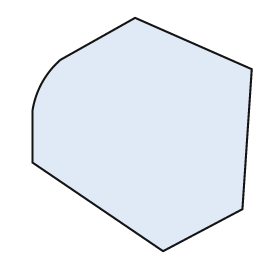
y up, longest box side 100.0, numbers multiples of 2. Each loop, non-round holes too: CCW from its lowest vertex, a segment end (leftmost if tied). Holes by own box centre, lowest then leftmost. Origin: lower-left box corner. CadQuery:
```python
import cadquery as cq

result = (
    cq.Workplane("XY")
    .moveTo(56.0, 0.0)
    .lineTo(90.0, 18.0)
    .lineTo(94.0, 78.0)
    .lineTo(44.0, 100.0)
    .lineTo(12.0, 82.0)
    .threePointArc((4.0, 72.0), (0.0, 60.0))
    .lineTo(0.0, 38.0)
    .close()
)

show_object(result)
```